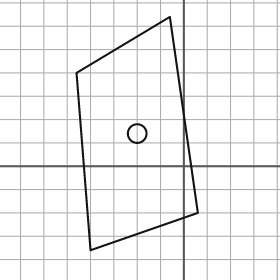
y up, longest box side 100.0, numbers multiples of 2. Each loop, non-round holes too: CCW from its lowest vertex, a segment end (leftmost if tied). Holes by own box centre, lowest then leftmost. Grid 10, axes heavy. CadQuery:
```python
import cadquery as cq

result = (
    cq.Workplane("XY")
    .moveTo(-40.0, -36.0)
    .lineTo(6.0, -20.0)
    .lineTo(-6.0, 64.0)
    .lineTo(-46.0, 40.0)
    .close()
    .moveTo(-20.0, 14.0)
    .circle(4.0)
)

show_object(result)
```